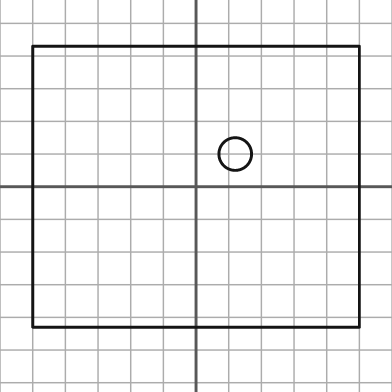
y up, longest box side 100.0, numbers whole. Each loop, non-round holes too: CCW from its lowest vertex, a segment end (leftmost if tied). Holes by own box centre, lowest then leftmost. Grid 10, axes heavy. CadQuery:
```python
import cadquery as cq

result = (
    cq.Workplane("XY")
    .moveTo(-50.0, -43.0)
    .lineTo(50.0, -43.0)
    .lineTo(50.0, 43.0)
    .lineTo(-50.0, 43.0)
    .close()
    .moveTo(12.0, 10.0)
    .circle(5.0)
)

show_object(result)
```